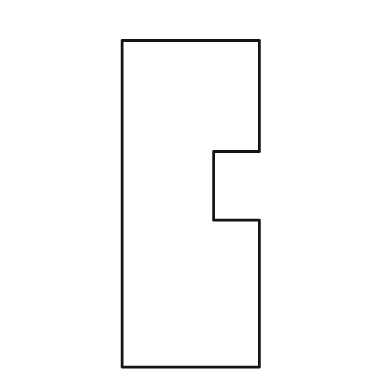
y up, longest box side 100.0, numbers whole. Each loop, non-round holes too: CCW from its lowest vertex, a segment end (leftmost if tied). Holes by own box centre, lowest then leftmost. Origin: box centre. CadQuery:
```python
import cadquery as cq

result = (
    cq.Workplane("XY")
    .moveTo(-21.0, -50.0)
    .lineTo(21.0, -50.0)
    .lineTo(21.0, -5.0)
    .lineTo(7.0, -5.0)
    .lineTo(7.0, 16.0)
    .lineTo(21.0, 16.0)
    .lineTo(21.0, 50.0)
    .lineTo(-21.0, 50.0)
    .close()
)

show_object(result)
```